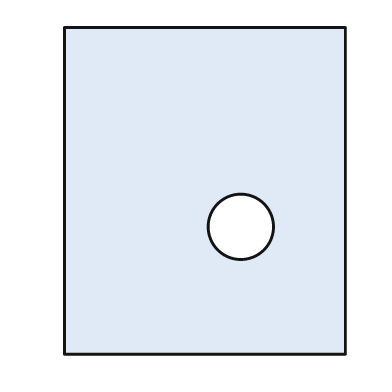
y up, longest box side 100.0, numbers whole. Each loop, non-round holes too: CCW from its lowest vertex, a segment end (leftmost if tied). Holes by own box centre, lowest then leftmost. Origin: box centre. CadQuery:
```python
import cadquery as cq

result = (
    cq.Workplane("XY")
    .moveTo(-43.0, -50.0)
    .lineTo(43.0, -50.0)
    .lineTo(43.0, 50.0)
    .lineTo(-43.0, 50.0)
    .close()
    .moveTo(11.0, -11.0)
    .circle(10.0)
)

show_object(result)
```